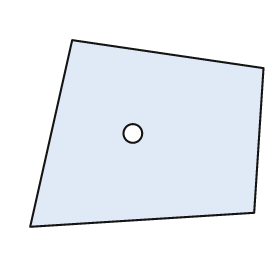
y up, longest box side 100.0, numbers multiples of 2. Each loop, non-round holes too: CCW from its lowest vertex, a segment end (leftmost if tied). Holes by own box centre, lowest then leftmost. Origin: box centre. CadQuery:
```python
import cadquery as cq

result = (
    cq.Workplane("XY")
    .moveTo(-50.0, -40.0)
    .lineTo(46.0, -34.0)
    .lineTo(50.0, 28.0)
    .lineTo(-32.0, 40.0)
    .close()
    .moveTo(-6.0, 0.0)
    .circle(4.0)
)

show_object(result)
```